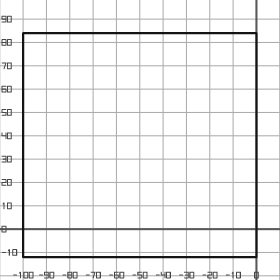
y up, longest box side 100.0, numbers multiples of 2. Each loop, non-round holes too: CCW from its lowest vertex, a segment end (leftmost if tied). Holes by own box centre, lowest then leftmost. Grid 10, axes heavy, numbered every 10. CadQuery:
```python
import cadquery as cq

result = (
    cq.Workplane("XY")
    .moveTo(-100.0, -12.0)
    .lineTo(0.0, -12.0)
    .lineTo(0.0, 84.0)
    .lineTo(-100.0, 84.0)
    .close()
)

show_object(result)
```